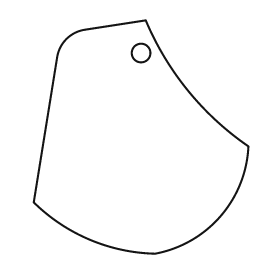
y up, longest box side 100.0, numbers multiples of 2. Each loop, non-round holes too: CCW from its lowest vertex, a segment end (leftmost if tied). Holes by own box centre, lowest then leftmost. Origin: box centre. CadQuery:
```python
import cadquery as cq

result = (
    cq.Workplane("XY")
    .moveTo(6.0, -50.0)
    .threePointArc((34.0, -34.0), (46.0, -4.0))
    .threePointArc((20.0, 20.0), (2.0, 50.0))
    .lineTo(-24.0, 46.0)
    .threePointArc((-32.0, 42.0), (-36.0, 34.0))
    .lineTo(-46.0, -28.0)
    .threePointArc((-22.0, -44.0), (6.0, -50.0))
    .close()
    .moveTo(0.0, 36.0)
    .circle(4.0)
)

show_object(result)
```